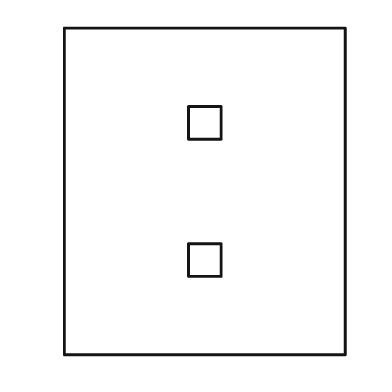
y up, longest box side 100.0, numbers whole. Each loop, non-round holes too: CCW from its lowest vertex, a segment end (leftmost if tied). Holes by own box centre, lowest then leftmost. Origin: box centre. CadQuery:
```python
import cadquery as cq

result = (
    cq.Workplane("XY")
    .moveTo(-43.0, -50.0)
    .lineTo(43.0, -50.0)
    .lineTo(43.0, 50.0)
    .lineTo(-43.0, 50.0)
    .close()
    .moveTo(-5.0, -26.0)
    .lineTo(5.0, -26.0)
    .lineTo(5.0, -16.0)
    .lineTo(-5.0, -16.0)
    .close()
    .moveTo(-5.0, 16.0)
    .lineTo(5.0, 16.0)
    .lineTo(5.0, 26.0)
    .lineTo(-5.0, 26.0)
    .close()
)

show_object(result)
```